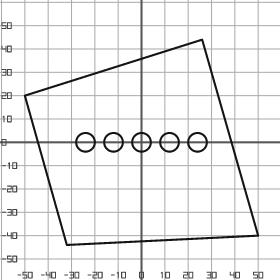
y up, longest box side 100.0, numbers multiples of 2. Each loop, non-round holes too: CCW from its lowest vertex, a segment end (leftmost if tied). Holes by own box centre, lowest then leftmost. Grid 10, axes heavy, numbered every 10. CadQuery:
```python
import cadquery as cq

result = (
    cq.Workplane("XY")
    .moveTo(-32.0, -44.0)
    .lineTo(50.0, -40.0)
    .lineTo(26.0, 44.0)
    .lineTo(-50.0, 20.0)
    .close()
    .moveTo(-24.0, 0.0)
    .circle(4.0)
    .moveTo(-12.0, 0.0)
    .circle(4.0)
    .moveTo(0.0, 0.0)
    .circle(4.0)
    .moveTo(12.0, 0.0)
    .circle(4.0)
    .moveTo(24.0, 0.0)
    .circle(4.0)
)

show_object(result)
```